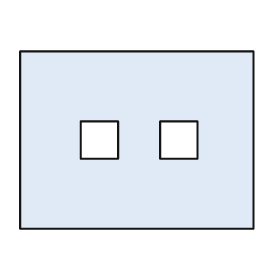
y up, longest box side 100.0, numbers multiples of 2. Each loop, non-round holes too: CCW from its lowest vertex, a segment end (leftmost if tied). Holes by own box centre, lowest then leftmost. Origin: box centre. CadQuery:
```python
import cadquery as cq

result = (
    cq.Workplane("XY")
    .moveTo(-50.0, -38.0)
    .lineTo(50.0, -38.0)
    .lineTo(50.0, 38.0)
    .lineTo(-50.0, 38.0)
    .close()
    .moveTo(-24.0, -8.0)
    .lineTo(-8.0, -8.0)
    .lineTo(-8.0, 8.0)
    .lineTo(-24.0, 8.0)
    .close()
    .moveTo(10.0, -8.0)
    .lineTo(26.0, -8.0)
    .lineTo(26.0, 8.0)
    .lineTo(10.0, 8.0)
    .close()
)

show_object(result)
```